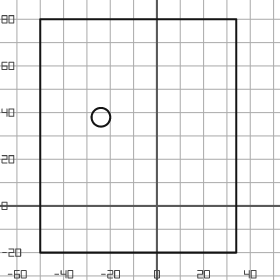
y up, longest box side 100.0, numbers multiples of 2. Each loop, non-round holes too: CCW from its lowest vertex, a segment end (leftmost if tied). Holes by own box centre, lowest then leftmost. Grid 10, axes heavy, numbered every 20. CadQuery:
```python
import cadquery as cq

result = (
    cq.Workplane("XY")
    .moveTo(-50.0, -20.0)
    .lineTo(34.0, -20.0)
    .lineTo(34.0, 80.0)
    .lineTo(-50.0, 80.0)
    .close()
    .moveTo(-24.0, 38.0)
    .circle(4.0)
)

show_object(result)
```